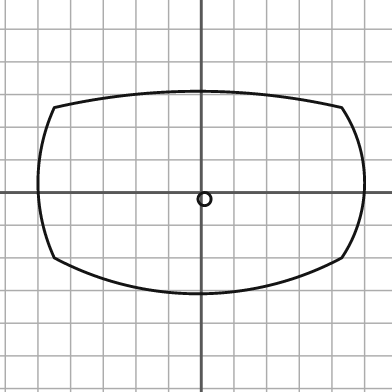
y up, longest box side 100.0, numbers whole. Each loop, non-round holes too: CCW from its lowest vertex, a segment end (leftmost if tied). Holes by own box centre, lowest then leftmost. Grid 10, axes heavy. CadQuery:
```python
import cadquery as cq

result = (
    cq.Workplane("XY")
    .moveTo(-45.0, -20.0)
    .threePointArc((-1.0, -31.0), (43.0, -20.0))
    .threePointArc((50.0, 3.0), (43.0, 26.0))
    .threePointArc((-1.0, 31.0), (-45.0, 26.0))
    .threePointArc((-50.0, 3.0), (-45.0, -20.0))
    .close()
    .moveTo(1.0, -2.0)
    .circle(2.0)
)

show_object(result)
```